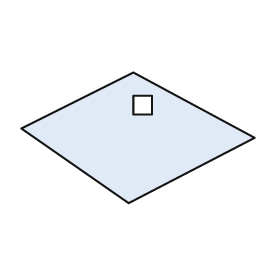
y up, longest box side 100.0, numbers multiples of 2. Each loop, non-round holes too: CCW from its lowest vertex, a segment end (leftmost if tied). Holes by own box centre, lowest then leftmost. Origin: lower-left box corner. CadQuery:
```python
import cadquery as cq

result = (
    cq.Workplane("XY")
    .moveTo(46.0, 0.0)
    .lineTo(100.0, 28.0)
    .lineTo(48.0, 56.0)
    .lineTo(0.0, 32.0)
    .close()
    .moveTo(48.0, 38.0)
    .lineTo(56.0, 38.0)
    .lineTo(56.0, 46.0)
    .lineTo(48.0, 46.0)
    .close()
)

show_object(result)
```